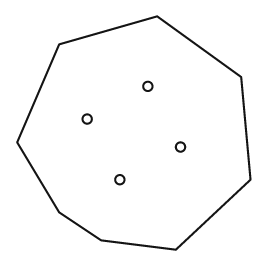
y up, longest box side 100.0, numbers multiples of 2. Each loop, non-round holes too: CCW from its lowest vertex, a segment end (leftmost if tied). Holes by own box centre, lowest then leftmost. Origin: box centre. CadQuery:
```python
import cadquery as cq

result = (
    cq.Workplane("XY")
    .moveTo(18.0, -50.0)
    .lineTo(50.0, -20.0)
    .lineTo(46.0, 24.0)
    .lineTo(10.0, 50.0)
    .lineTo(-32.0, 38.0)
    .lineTo(-50.0, -4.0)
    .lineTo(-32.0, -34.0)
    .lineTo(-14.0, -46.0)
    .close()
    .moveTo(-6.0, -20.0)
    .circle(2.0)
    .moveTo(20.0, -6.0)
    .circle(2.0)
    .moveTo(-20.0, 6.0)
    .circle(2.0)
    .moveTo(6.0, 20.0)
    .circle(2.0)
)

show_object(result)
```